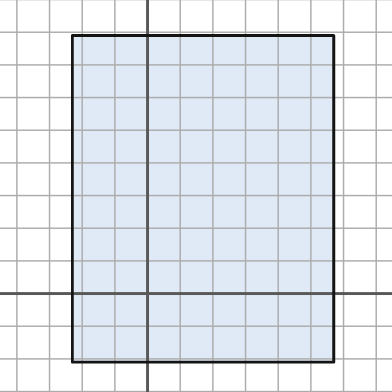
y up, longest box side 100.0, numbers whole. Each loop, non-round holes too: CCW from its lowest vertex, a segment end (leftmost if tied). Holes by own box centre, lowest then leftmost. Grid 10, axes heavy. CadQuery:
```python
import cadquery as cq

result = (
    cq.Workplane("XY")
    .moveTo(-23.0, -21.0)
    .lineTo(57.0, -21.0)
    .lineTo(57.0, 79.0)
    .lineTo(-23.0, 79.0)
    .close()
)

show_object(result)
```